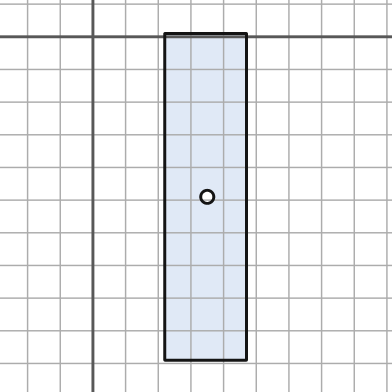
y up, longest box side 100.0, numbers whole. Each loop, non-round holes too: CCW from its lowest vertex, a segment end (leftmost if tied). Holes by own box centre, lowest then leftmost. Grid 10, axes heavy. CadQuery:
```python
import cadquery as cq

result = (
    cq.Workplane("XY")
    .moveTo(22.0, -99.0)
    .lineTo(47.0, -99.0)
    .lineTo(47.0, 1.0)
    .lineTo(22.0, 1.0)
    .close()
    .moveTo(35.0, -49.0)
    .circle(2.0)
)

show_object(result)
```